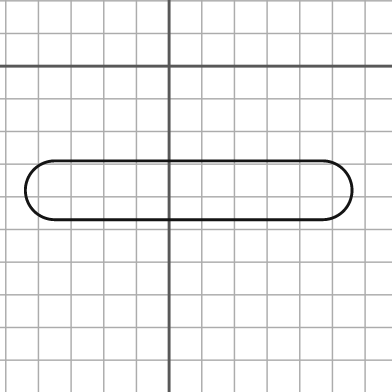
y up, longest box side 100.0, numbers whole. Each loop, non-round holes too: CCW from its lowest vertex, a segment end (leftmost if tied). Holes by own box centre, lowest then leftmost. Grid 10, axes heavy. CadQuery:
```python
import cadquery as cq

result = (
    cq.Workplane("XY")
    .moveTo(-35.0, -47.0)
    .lineTo(47.0, -47.0)
    .threePointArc((56.0, -38.0), (47.0, -29.0))
    .lineTo(-35.0, -29.0)
    .threePointArc((-44.0, -38.0), (-35.0, -47.0))
    .close()
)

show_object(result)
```